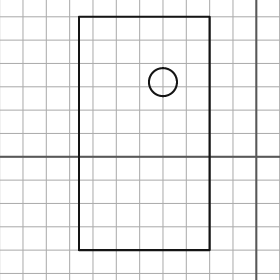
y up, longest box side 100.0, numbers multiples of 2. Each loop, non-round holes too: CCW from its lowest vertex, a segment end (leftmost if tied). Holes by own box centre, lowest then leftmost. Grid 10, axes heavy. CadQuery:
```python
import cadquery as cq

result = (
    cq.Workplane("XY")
    .moveTo(-76.0, -40.0)
    .lineTo(-20.0, -40.0)
    .lineTo(-20.0, 60.0)
    .lineTo(-76.0, 60.0)
    .close()
    .moveTo(-40.0, 32.0)
    .circle(6.0)
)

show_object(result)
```